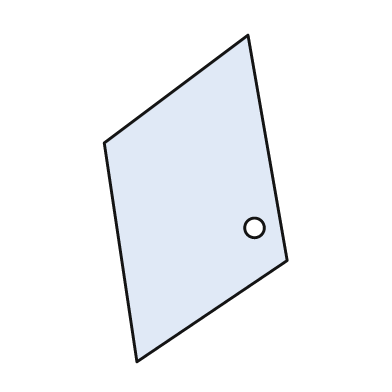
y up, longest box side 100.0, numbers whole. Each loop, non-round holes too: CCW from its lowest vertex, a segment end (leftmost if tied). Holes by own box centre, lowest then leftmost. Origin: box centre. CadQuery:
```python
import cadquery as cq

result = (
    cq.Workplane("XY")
    .moveTo(-18.0, -50.0)
    .lineTo(28.0, -19.0)
    .lineTo(16.0, 50.0)
    .lineTo(-28.0, 17.0)
    .close()
    .moveTo(18.0, -9.0)
    .circle(3.0)
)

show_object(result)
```